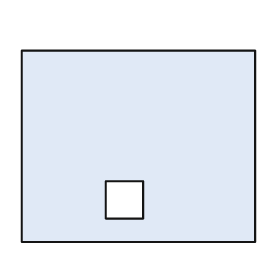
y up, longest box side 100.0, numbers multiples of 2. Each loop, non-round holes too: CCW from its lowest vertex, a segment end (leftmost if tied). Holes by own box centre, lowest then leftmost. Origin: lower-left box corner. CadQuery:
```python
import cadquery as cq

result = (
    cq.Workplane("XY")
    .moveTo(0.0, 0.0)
    .lineTo(100.0, 0.0)
    .lineTo(100.0, 82.0)
    .lineTo(0.0, 82.0)
    .close()
    .moveTo(36.0, 10.0)
    .lineTo(52.0, 10.0)
    .lineTo(52.0, 26.0)
    .lineTo(36.0, 26.0)
    .close()
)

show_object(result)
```